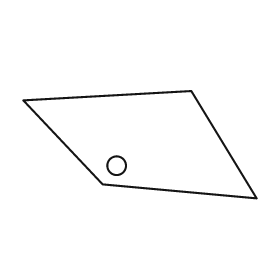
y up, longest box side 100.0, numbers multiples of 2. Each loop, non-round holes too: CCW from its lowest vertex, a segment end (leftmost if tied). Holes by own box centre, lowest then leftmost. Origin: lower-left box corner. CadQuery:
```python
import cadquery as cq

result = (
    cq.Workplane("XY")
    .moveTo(100.0, 0.0)
    .lineTo(72.0, 46.0)
    .lineTo(0.0, 42.0)
    .lineTo(34.0, 6.0)
    .close()
    .moveTo(40.0, 14.0)
    .circle(4.0)
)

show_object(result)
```